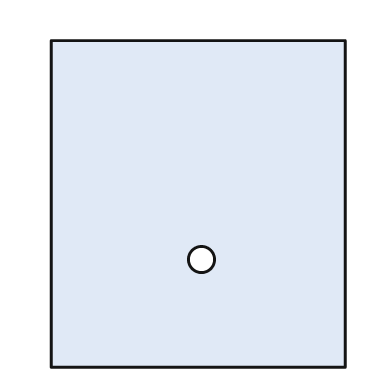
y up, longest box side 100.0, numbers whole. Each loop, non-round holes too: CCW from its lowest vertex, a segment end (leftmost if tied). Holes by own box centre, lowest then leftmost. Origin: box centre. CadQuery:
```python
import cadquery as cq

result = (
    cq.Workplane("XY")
    .moveTo(-45.0, -50.0)
    .lineTo(45.0, -50.0)
    .lineTo(45.0, 50.0)
    .lineTo(-45.0, 50.0)
    .close()
    .moveTo(1.0, -17.0)
    .circle(4.0)
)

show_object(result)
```